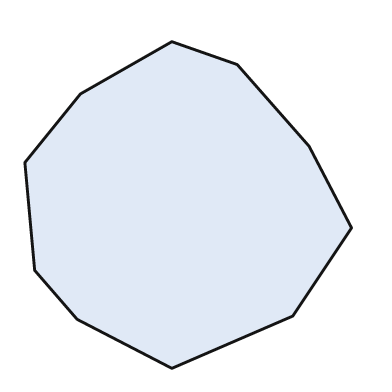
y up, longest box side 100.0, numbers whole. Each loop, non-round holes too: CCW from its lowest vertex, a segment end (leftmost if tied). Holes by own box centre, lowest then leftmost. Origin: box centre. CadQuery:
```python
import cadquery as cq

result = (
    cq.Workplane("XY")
    .moveTo(-5.0, -50.0)
    .lineTo(32.0, -34.0)
    .lineTo(50.0, -7.0)
    .lineTo(37.0, 18.0)
    .lineTo(15.0, 43.0)
    .lineTo(-5.0, 50.0)
    .lineTo(-33.0, 34.0)
    .lineTo(-50.0, 13.0)
    .lineTo(-47.0, -20.0)
    .lineTo(-34.0, -35.0)
    .close()
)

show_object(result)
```